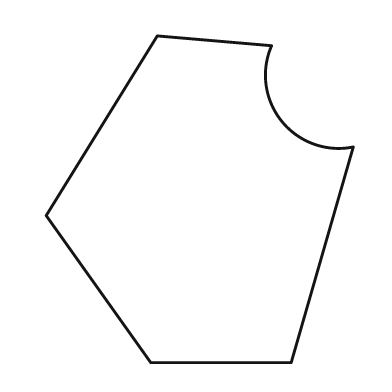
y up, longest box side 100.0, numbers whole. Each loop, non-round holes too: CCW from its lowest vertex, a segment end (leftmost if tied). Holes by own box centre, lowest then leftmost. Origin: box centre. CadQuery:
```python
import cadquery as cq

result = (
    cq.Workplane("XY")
    .moveTo(-15.0, -50.0)
    .lineTo(28.0, -50.0)
    .lineTo(47.0, 16.0)
    .threePointArc((25.0, 24.0), (22.0, 47.0))
    .lineTo(-13.0, 50.0)
    .lineTo(-47.0, -5.0)
    .close()
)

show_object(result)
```